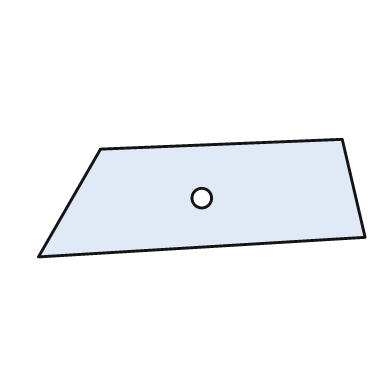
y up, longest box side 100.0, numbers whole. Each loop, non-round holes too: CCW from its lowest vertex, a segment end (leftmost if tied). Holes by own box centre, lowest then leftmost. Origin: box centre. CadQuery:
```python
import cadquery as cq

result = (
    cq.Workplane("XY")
    .moveTo(-50.0, -18.0)
    .lineTo(50.0, -12.0)
    .lineTo(43.0, 18.0)
    .lineTo(-31.0, 15.0)
    .close()
    .moveTo(0.0, 0.0)
    .circle(3.0)
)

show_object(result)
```